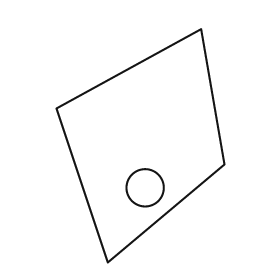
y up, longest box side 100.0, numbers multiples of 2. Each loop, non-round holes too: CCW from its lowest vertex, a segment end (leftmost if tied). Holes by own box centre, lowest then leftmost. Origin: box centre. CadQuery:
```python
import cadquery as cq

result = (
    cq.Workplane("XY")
    .moveTo(-14.0, -50.0)
    .lineTo(36.0, -8.0)
    .lineTo(26.0, 50.0)
    .lineTo(-36.0, 16.0)
    .close()
    .moveTo(2.0, -18.0)
    .circle(8.0)
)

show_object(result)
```